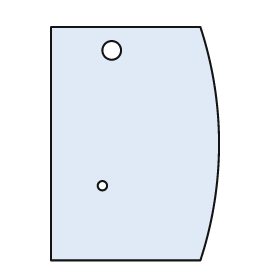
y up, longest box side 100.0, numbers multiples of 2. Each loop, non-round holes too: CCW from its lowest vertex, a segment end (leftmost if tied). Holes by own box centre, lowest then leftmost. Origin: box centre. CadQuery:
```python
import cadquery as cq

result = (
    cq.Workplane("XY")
    .moveTo(-36.0, -50.0)
    .lineTo(28.0, -50.0)
    .threePointArc((36.0, 0.0), (28.0, 50.0))
    .lineTo(-36.0, 50.0)
    .close()
    .moveTo(-14.0, -18.0)
    .circle(2.0)
    .moveTo(-10.0, 40.0)
    .circle(4.0)
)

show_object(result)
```